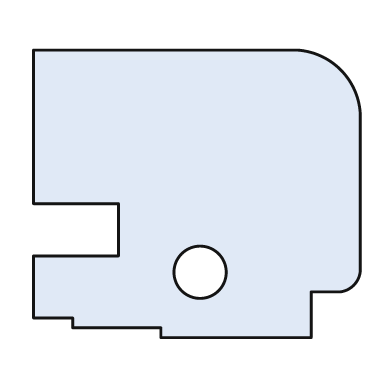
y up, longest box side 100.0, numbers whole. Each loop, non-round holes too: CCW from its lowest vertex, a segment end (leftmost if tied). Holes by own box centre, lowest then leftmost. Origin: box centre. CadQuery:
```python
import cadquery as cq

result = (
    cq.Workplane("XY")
    .moveTo(-11.0, -44.0)
    .lineTo(35.0, -44.0)
    .lineTo(35.0, -30.0)
    .lineTo(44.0, -30.0)
    .threePointArc((48.0, -28.0), (50.0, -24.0))
    .lineTo(50.0, 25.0)
    .threePointArc((44.0, 38.0), (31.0, 44.0))
    .lineTo(-50.0, 44.0)
    .lineTo(-50.0, -3.0)
    .lineTo(-24.0, -3.0)
    .lineTo(-24.0, -19.0)
    .lineTo(-50.0, -19.0)
    .lineTo(-50.0, -38.0)
    .lineTo(-38.0, -38.0)
    .lineTo(-38.0, -41.0)
    .lineTo(-11.0, -41.0)
    .close()
    .moveTo(1.0, -24.0)
    .circle(8.0)
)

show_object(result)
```